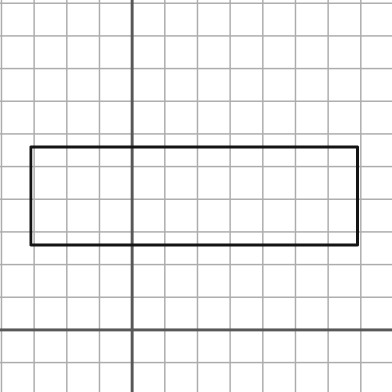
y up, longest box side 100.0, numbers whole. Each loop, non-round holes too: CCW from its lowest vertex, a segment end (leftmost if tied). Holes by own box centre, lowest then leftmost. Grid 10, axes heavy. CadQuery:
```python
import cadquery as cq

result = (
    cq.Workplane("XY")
    .moveTo(-31.0, 26.0)
    .lineTo(69.0, 26.0)
    .lineTo(69.0, 56.0)
    .lineTo(-31.0, 56.0)
    .close()
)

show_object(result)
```